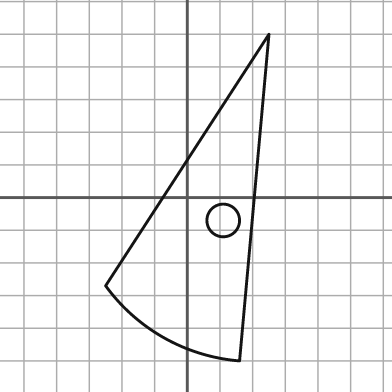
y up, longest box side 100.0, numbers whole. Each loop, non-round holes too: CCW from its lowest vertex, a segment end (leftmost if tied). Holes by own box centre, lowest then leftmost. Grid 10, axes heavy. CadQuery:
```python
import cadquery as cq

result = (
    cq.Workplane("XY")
    .moveTo(16.0, -50.0)
    .lineTo(25.0, 50.0)
    .lineTo(-25.0, -27.0)
    .threePointArc((-7.0, -43.0), (16.0, -50.0))
    .close()
    .moveTo(11.0, -7.0)
    .circle(5.0)
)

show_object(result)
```